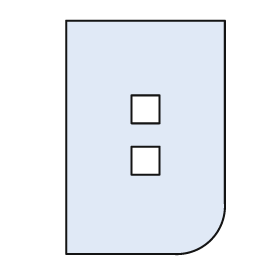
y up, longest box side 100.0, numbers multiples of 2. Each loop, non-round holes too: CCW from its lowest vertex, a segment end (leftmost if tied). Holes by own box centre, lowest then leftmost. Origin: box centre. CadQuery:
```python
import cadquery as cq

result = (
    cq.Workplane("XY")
    .moveTo(-34.0, -50.0)
    .lineTo(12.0, -50.0)
    .threePointArc((28.0, -44.0), (34.0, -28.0))
    .lineTo(34.0, 50.0)
    .lineTo(-34.0, 50.0)
    .close()
    .moveTo(-6.0, -16.0)
    .lineTo(6.0, -16.0)
    .lineTo(6.0, -4.0)
    .lineTo(-6.0, -4.0)
    .close()
    .moveTo(-6.0, 6.0)
    .lineTo(6.0, 6.0)
    .lineTo(6.0, 18.0)
    .lineTo(-6.0, 18.0)
    .close()
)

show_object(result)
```